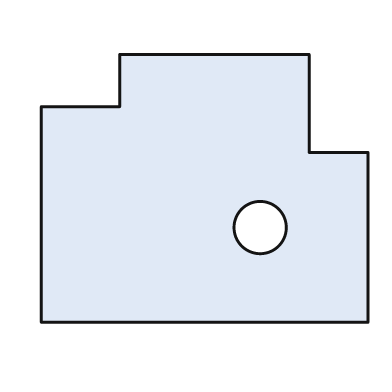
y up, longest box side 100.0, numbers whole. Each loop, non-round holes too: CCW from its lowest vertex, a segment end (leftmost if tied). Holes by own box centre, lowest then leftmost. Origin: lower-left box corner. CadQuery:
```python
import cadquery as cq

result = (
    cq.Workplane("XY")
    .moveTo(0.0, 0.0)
    .lineTo(100.0, 0.0)
    .lineTo(100.0, 52.0)
    .lineTo(82.0, 52.0)
    .lineTo(82.0, 82.0)
    .lineTo(24.0, 82.0)
    .lineTo(24.0, 66.0)
    .lineTo(0.0, 66.0)
    .close()
    .moveTo(67.0, 29.0)
    .circle(8.0)
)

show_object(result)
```